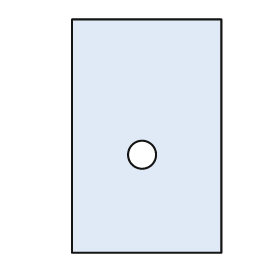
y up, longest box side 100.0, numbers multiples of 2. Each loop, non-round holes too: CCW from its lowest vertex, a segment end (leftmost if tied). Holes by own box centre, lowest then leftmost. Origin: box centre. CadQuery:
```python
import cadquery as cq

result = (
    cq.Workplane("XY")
    .moveTo(-32.0, -50.0)
    .lineTo(32.0, -50.0)
    .lineTo(32.0, 50.0)
    .lineTo(-32.0, 50.0)
    .close()
    .moveTo(-2.0, -8.0)
    .circle(6.0)
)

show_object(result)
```